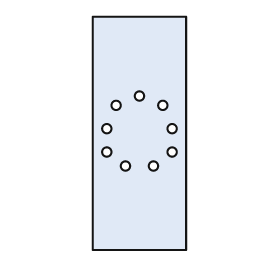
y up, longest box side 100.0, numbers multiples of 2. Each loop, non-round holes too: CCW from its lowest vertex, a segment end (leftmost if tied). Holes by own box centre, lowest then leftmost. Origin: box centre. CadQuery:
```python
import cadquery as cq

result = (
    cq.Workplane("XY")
    .moveTo(-20.0, -50.0)
    .lineTo(20.0, -50.0)
    .lineTo(20.0, 50.0)
    .lineTo(-20.0, 50.0)
    .close()
    .moveTo(-6.0, -14.0)
    .circle(2.0)
    .moveTo(6.0, -14.0)
    .circle(2.0)
    .moveTo(-14.0, -8.0)
    .circle(2.0)
    .moveTo(14.0, -8.0)
    .circle(2.0)
    .moveTo(-14.0, 2.0)
    .circle(2.0)
    .moveTo(14.0, 2.0)
    .circle(2.0)
    .moveTo(-10.0, 12.0)
    .circle(2.0)
    .moveTo(10.0, 12.0)
    .circle(2.0)
    .moveTo(0.0, 16.0)
    .circle(2.0)
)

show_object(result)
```